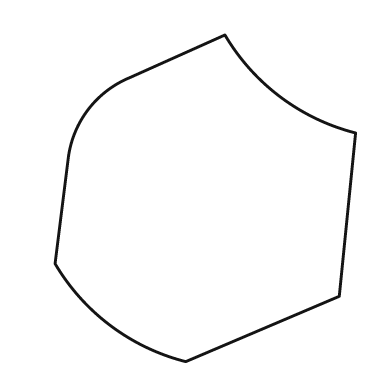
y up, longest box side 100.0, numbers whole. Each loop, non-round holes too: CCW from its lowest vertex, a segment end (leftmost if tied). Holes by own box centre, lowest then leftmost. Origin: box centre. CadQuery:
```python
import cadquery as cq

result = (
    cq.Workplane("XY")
    .moveTo(-6.0, -50.0)
    .lineTo(41.0, -30.0)
    .lineTo(46.0, 20.0)
    .threePointArc((23.0, 31.0), (6.0, 50.0))
    .lineTo(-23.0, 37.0)
    .threePointArc((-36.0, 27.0), (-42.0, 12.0))
    .lineTo(-46.0, -20.0)
    .threePointArc((-29.0, -39.0), (-6.0, -50.0))
    .close()
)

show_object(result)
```